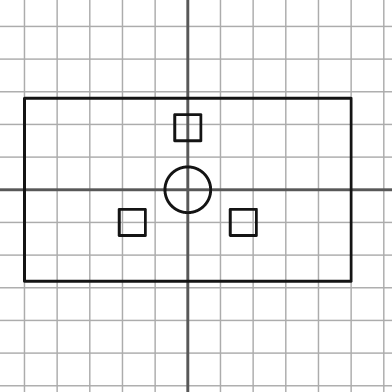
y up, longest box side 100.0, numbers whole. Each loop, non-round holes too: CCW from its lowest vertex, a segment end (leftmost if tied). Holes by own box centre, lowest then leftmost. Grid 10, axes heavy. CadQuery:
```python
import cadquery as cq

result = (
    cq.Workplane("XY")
    .moveTo(-50.0, -28.0)
    .lineTo(50.0, -28.0)
    .lineTo(50.0, 28.0)
    .lineTo(-50.0, 28.0)
    .close()
    .moveTo(-21.0, -14.0)
    .lineTo(-13.0, -14.0)
    .lineTo(-13.0, -6.0)
    .lineTo(-21.0, -6.0)
    .close()
    .moveTo(13.0, -14.0)
    .lineTo(21.0, -14.0)
    .lineTo(21.0, -6.0)
    .lineTo(13.0, -6.0)
    .close()
    .moveTo(0.0, 0.0)
    .circle(7.0)
    .moveTo(-4.0, 15.0)
    .lineTo(4.0, 15.0)
    .lineTo(4.0, 23.0)
    .lineTo(-4.0, 23.0)
    .close()
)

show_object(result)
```